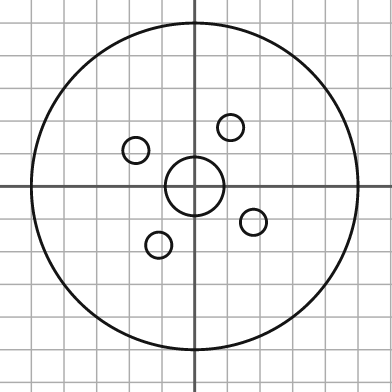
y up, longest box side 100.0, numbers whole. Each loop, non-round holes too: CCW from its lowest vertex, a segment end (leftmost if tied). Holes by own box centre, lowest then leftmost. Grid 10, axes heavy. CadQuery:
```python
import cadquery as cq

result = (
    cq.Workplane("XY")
    .moveTo(0.0, 0.0)
    .circle(50.0)
    .moveTo(-11.0, -18.0)
    .circle(4.0)
    .moveTo(18.0, -11.0)
    .circle(4.0)
    .moveTo(0.0, 0.0)
    .circle(9.0)
    .moveTo(-18.0, 11.0)
    .circle(4.0)
    .moveTo(11.0, 18.0)
    .circle(4.0)
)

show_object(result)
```